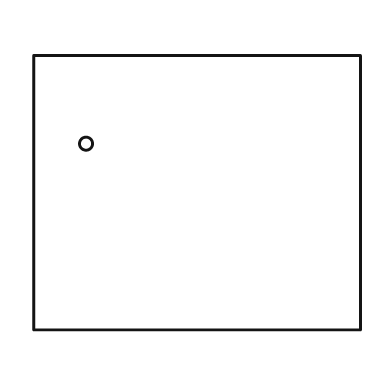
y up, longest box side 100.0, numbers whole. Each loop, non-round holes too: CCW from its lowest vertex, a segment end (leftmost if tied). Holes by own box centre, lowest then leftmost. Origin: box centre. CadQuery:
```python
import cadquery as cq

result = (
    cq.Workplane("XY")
    .moveTo(-50.0, -42.0)
    .lineTo(50.0, -42.0)
    .lineTo(50.0, 42.0)
    .lineTo(-50.0, 42.0)
    .close()
    .moveTo(-34.0, 15.0)
    .circle(2.0)
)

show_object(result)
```